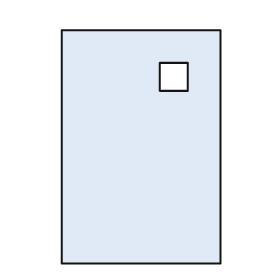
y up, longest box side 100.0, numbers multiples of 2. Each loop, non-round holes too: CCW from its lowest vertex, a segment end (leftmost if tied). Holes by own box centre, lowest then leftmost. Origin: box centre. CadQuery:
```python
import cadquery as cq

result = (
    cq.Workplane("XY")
    .moveTo(-34.0, -50.0)
    .lineTo(34.0, -50.0)
    .lineTo(34.0, 50.0)
    .lineTo(-34.0, 50.0)
    .close()
    .moveTo(8.0, 24.0)
    .lineTo(20.0, 24.0)
    .lineTo(20.0, 36.0)
    .lineTo(8.0, 36.0)
    .close()
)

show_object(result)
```